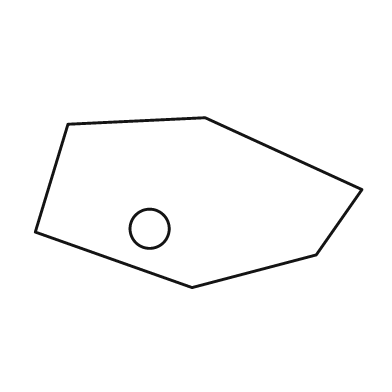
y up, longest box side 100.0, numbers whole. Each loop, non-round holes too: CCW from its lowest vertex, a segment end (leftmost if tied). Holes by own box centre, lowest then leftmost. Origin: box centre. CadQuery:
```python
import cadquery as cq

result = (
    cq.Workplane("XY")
    .moveTo(-2.0, -26.0)
    .lineTo(36.0, -16.0)
    .lineTo(50.0, 4.0)
    .lineTo(2.0, 26.0)
    .lineTo(-40.0, 24.0)
    .lineTo(-50.0, -9.0)
    .close()
    .moveTo(-15.0, -8.0)
    .circle(6.0)
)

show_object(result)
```